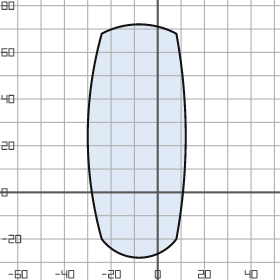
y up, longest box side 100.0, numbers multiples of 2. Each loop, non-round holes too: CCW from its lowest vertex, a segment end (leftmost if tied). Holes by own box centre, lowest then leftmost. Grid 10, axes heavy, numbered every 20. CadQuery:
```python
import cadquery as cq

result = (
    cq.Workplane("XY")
    .moveTo(-24.0, -20.0)
    .threePointArc((-8.0, -28.0), (8.0, -20.0))
    .threePointArc((12.0, 24.0), (8.0, 68.0))
    .threePointArc((-8.0, 72.0), (-24.0, 68.0))
    .threePointArc((-30.0, 24.0), (-24.0, -20.0))
    .close()
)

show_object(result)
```